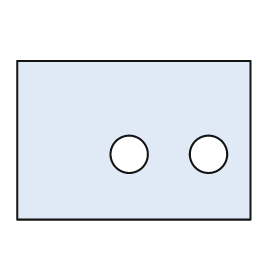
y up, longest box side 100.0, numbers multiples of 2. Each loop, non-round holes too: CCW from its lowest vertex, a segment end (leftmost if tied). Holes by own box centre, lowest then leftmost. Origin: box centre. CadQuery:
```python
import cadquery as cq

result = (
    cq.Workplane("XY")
    .moveTo(-50.0, -34.0)
    .lineTo(50.0, -34.0)
    .lineTo(50.0, 34.0)
    .lineTo(-50.0, 34.0)
    .close()
    .moveTo(-2.0, -6.0)
    .circle(8.0)
    .moveTo(32.0, -6.0)
    .circle(8.0)
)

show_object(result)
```